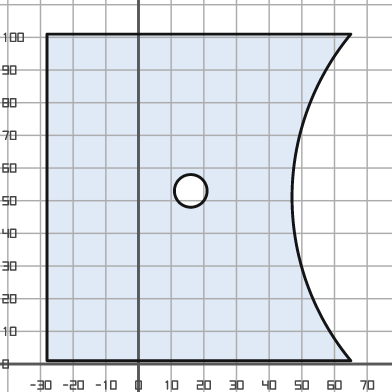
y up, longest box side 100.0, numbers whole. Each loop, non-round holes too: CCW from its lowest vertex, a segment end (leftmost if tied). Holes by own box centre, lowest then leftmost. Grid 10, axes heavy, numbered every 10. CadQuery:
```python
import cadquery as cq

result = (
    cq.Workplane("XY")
    .moveTo(-28.0, 1.0)
    .lineTo(65.0, 1.0)
    .threePointArc((47.0, 51.0), (65.0, 101.0))
    .lineTo(-28.0, 101.0)
    .close()
    .moveTo(16.0, 53.0)
    .circle(5.0)
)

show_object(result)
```